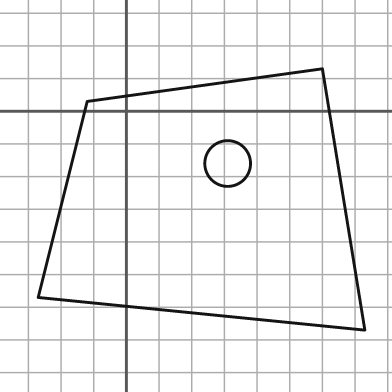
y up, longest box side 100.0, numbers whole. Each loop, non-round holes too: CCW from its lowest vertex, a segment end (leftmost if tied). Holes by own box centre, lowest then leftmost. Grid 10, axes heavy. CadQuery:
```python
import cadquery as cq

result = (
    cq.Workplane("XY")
    .moveTo(73.0, -67.0)
    .lineTo(60.0, 13.0)
    .lineTo(-12.0, 3.0)
    .lineTo(-27.0, -57.0)
    .close()
    .moveTo(31.0, -16.0)
    .circle(7.0)
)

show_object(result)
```